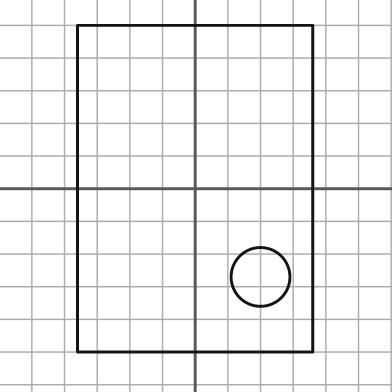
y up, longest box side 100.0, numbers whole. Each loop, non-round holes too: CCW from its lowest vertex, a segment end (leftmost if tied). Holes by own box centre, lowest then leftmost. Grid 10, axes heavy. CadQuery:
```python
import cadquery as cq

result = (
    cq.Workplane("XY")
    .moveTo(-36.0, -50.0)
    .lineTo(36.0, -50.0)
    .lineTo(36.0, 50.0)
    .lineTo(-36.0, 50.0)
    .close()
    .moveTo(20.0, -27.0)
    .circle(9.0)
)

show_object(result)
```